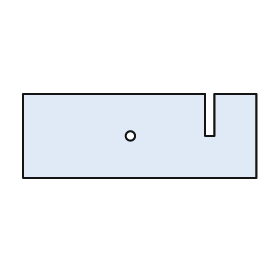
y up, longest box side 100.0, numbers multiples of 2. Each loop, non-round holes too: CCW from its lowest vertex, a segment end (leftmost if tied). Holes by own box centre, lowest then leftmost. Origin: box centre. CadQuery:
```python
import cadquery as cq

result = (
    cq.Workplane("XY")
    .moveTo(-50.0, -18.0)
    .lineTo(50.0, -18.0)
    .lineTo(50.0, 18.0)
    .lineTo(32.0, 18.0)
    .lineTo(32.0, 0.0)
    .lineTo(28.0, 0.0)
    .lineTo(28.0, 18.0)
    .lineTo(-50.0, 18.0)
    .close()
    .moveTo(-4.0, 0.0)
    .circle(2.0)
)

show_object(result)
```